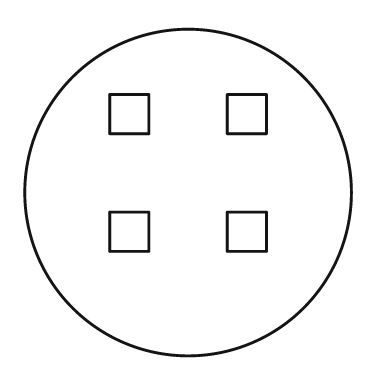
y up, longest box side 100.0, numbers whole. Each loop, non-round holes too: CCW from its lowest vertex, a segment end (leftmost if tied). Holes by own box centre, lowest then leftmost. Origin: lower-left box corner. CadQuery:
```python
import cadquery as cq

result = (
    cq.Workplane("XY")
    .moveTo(50.0, 50.0)
    .circle(50.0)
    .moveTo(26.0, 32.0)
    .lineTo(38.0, 32.0)
    .lineTo(38.0, 44.0)
    .lineTo(26.0, 44.0)
    .close()
    .moveTo(62.0, 32.0)
    .lineTo(74.0, 32.0)
    .lineTo(74.0, 44.0)
    .lineTo(62.0, 44.0)
    .close()
    .moveTo(26.0, 68.0)
    .lineTo(38.0, 68.0)
    .lineTo(38.0, 80.0)
    .lineTo(26.0, 80.0)
    .close()
    .moveTo(62.0, 68.0)
    .lineTo(74.0, 68.0)
    .lineTo(74.0, 80.0)
    .lineTo(62.0, 80.0)
    .close()
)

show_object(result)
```